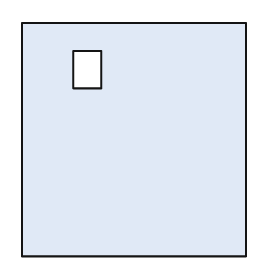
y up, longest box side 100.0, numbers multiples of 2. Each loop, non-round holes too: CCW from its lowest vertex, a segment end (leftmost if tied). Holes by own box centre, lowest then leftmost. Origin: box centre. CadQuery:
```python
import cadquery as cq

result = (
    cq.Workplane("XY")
    .moveTo(-48.0, -50.0)
    .lineTo(48.0, -50.0)
    .lineTo(48.0, 50.0)
    .lineTo(-48.0, 50.0)
    .close()
    .moveTo(-26.0, 22.0)
    .lineTo(-14.0, 22.0)
    .lineTo(-14.0, 38.0)
    .lineTo(-26.0, 38.0)
    .close()
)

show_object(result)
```